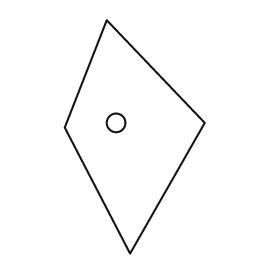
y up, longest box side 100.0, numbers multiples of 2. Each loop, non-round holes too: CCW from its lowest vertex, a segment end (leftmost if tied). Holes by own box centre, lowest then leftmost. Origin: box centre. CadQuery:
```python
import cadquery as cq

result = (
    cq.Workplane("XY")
    .moveTo(-2.0, -50.0)
    .lineTo(30.0, 6.0)
    .lineTo(-12.0, 50.0)
    .lineTo(-30.0, 4.0)
    .close()
    .moveTo(-8.0, 6.0)
    .circle(4.0)
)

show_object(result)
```